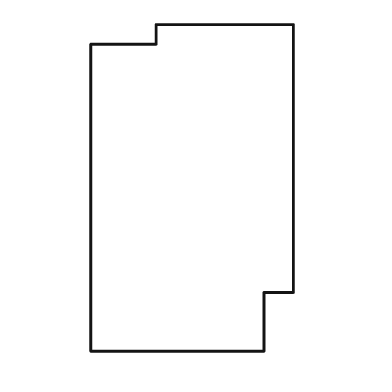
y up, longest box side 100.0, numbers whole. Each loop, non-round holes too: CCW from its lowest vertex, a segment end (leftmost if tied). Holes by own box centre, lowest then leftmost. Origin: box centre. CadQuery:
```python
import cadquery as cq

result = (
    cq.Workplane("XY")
    .moveTo(-31.0, -50.0)
    .lineTo(22.0, -50.0)
    .lineTo(22.0, -32.0)
    .lineTo(31.0, -32.0)
    .lineTo(31.0, 50.0)
    .lineTo(-11.0, 50.0)
    .lineTo(-11.0, 44.0)
    .lineTo(-31.0, 44.0)
    .close()
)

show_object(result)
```